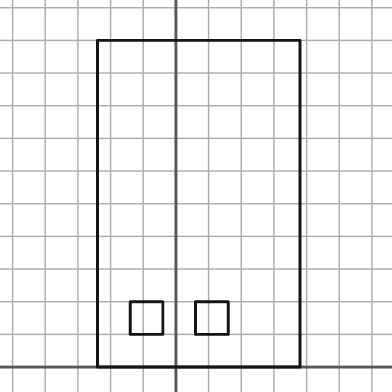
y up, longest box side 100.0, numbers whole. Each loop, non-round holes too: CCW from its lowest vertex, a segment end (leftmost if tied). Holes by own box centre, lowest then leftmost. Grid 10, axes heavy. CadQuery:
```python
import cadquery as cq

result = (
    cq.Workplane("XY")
    .moveTo(-24.0, 0.0)
    .lineTo(38.0, 0.0)
    .lineTo(38.0, 100.0)
    .lineTo(-24.0, 100.0)
    .close()
    .moveTo(-14.0, 10.0)
    .lineTo(-4.0, 10.0)
    .lineTo(-4.0, 20.0)
    .lineTo(-14.0, 20.0)
    .close()
    .moveTo(6.0, 10.0)
    .lineTo(16.0, 10.0)
    .lineTo(16.0, 20.0)
    .lineTo(6.0, 20.0)
    .close()
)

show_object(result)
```